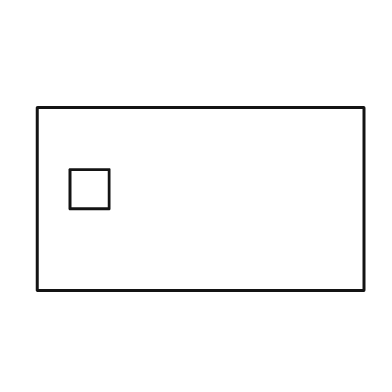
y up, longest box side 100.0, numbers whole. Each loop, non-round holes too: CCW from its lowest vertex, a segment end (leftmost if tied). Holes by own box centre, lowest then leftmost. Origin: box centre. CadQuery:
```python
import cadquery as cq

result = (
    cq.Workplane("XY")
    .moveTo(-50.0, -28.0)
    .lineTo(50.0, -28.0)
    .lineTo(50.0, 28.0)
    .lineTo(-50.0, 28.0)
    .close()
    .moveTo(-40.0, -3.0)
    .lineTo(-28.0, -3.0)
    .lineTo(-28.0, 9.0)
    .lineTo(-40.0, 9.0)
    .close()
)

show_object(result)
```